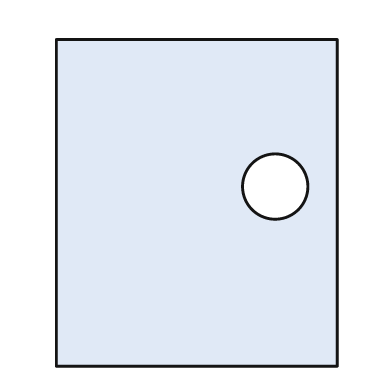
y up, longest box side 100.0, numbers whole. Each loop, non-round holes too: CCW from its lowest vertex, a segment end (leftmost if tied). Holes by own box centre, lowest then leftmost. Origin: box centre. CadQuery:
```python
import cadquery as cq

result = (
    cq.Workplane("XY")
    .moveTo(-43.0, -50.0)
    .lineTo(43.0, -50.0)
    .lineTo(43.0, 50.0)
    .lineTo(-43.0, 50.0)
    .close()
    .moveTo(24.0, 5.0)
    .circle(10.0)
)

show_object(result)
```